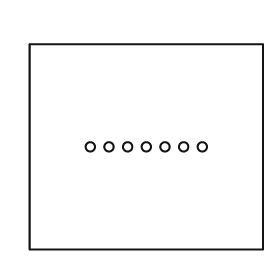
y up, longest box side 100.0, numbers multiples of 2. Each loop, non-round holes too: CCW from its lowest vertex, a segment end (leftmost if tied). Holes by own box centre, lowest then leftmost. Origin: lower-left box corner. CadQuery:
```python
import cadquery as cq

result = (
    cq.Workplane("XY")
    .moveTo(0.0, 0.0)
    .lineTo(100.0, 0.0)
    .lineTo(100.0, 88.0)
    .lineTo(0.0, 88.0)
    .close()
    .moveTo(26.0, 44.0)
    .circle(2.0)
    .moveTo(34.0, 44.0)
    .circle(2.0)
    .moveTo(42.0, 44.0)
    .circle(2.0)
    .moveTo(50.0, 44.0)
    .circle(2.0)
    .moveTo(58.0, 44.0)
    .circle(2.0)
    .moveTo(66.0, 44.0)
    .circle(2.0)
    .moveTo(74.0, 44.0)
    .circle(2.0)
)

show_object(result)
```